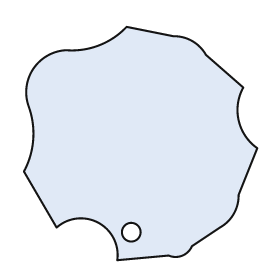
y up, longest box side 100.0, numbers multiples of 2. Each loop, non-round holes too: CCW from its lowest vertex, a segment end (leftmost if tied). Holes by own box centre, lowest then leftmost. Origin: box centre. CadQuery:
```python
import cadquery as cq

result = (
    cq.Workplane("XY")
    .moveTo(-10.0, -50.0)
    .lineTo(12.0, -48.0)
    .threePointArc((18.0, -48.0), (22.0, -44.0))
    .lineTo(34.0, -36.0)
    .threePointArc((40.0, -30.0), (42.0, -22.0))
    .lineTo(50.0, -2.0)
    .threePointArc((42.0, 10.0), (44.0, 24.0))
    .lineTo(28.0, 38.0)
    .threePointArc((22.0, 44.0), (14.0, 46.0))
    .lineTo(-6.0, 50.0)
    .threePointArc((-18.0, 42.0), (-32.0, 40.0))
    .threePointArc((-46.0, 32.0), (-48.0, 16.0))
    .threePointArc((-46.0, 2.0), (-50.0, -12.0))
    .lineTo(-36.0, -36.0)
    .threePointArc((-18.0, -34.0), (-10.0, -50.0))
    .close()
    .moveTo(-4.0, -38.0)
    .circle(4.0)
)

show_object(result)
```